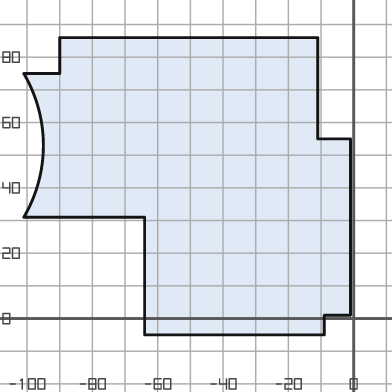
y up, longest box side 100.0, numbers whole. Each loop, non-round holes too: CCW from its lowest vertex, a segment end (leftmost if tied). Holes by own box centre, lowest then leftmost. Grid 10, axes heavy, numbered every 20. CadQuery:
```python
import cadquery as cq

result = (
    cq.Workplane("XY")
    .moveTo(-64.0, -5.0)
    .lineTo(-9.0, -5.0)
    .lineTo(-9.0, 1.0)
    .lineTo(-1.0, 1.0)
    .lineTo(-1.0, 55.0)
    .lineTo(-11.0, 55.0)
    .lineTo(-11.0, 86.0)
    .lineTo(-90.0, 86.0)
    .lineTo(-90.0, 75.0)
    .lineTo(-101.0, 75.0)
    .threePointArc((-95.0, 53.0), (-101.0, 31.0))
    .lineTo(-64.0, 31.0)
    .close()
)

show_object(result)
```